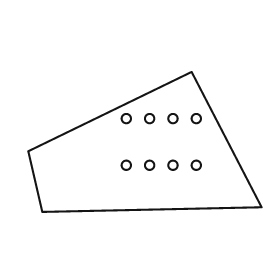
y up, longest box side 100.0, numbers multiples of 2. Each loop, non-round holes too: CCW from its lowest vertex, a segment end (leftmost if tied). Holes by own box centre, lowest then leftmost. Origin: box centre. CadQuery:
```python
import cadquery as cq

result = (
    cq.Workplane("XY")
    .moveTo(-44.0, -30.0)
    .lineTo(50.0, -28.0)
    .lineTo(20.0, 30.0)
    .lineTo(-50.0, -4.0)
    .close()
    .moveTo(-8.0, -10.0)
    .circle(2.0)
    .moveTo(2.0, -10.0)
    .circle(2.0)
    .moveTo(12.0, -10.0)
    .circle(2.0)
    .moveTo(22.0, -10.0)
    .circle(2.0)
    .moveTo(-8.0, 10.0)
    .circle(2.0)
    .moveTo(2.0, 10.0)
    .circle(2.0)
    .moveTo(12.0, 10.0)
    .circle(2.0)
    .moveTo(22.0, 10.0)
    .circle(2.0)
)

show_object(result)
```